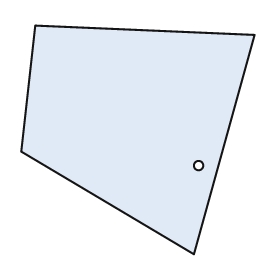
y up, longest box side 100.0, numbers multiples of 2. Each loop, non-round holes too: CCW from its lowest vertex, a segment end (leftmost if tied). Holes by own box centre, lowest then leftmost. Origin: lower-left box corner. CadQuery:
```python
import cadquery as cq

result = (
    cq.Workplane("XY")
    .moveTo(74.0, 0.0)
    .lineTo(100.0, 94.0)
    .lineTo(6.0, 98.0)
    .lineTo(0.0, 44.0)
    .close()
    .moveTo(76.0, 38.0)
    .circle(2.0)
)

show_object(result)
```